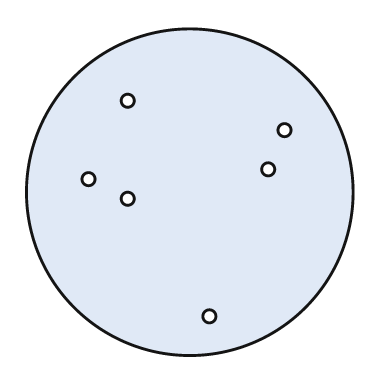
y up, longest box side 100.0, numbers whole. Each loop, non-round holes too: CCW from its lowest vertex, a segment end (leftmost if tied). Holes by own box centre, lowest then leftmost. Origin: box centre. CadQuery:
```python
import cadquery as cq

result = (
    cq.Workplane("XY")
    .moveTo(0.0, 0.0)
    .circle(50.0)
    .moveTo(6.0, -38.0)
    .circle(2.0)
    .moveTo(-19.0, -2.0)
    .circle(2.0)
    .moveTo(-31.0, 4.0)
    .circle(2.0)
    .moveTo(24.0, 7.0)
    .circle(2.0)
    .moveTo(29.0, 19.0)
    .circle(2.0)
    .moveTo(-19.0, 28.0)
    .circle(2.0)
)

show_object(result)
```